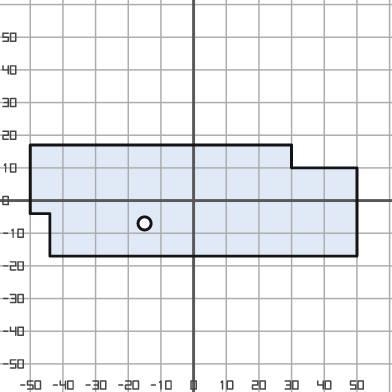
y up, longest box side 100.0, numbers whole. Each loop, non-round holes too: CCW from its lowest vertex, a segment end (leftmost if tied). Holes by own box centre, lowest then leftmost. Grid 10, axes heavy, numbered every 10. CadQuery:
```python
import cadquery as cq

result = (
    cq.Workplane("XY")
    .moveTo(-44.0, -17.0)
    .lineTo(50.0, -17.0)
    .lineTo(50.0, 10.0)
    .lineTo(30.0, 10.0)
    .lineTo(30.0, 17.0)
    .lineTo(-50.0, 17.0)
    .lineTo(-50.0, -4.0)
    .lineTo(-44.0, -4.0)
    .close()
    .moveTo(-15.0, -7.0)
    .circle(2.0)
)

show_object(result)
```